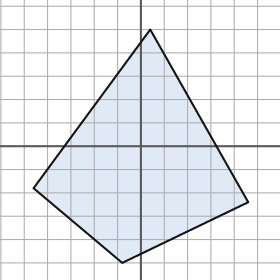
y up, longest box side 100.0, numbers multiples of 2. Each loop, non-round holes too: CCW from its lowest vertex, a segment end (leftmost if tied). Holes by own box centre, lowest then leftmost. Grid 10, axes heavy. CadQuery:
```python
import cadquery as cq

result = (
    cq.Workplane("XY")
    .moveTo(-8.0, -50.0)
    .lineTo(46.0, -24.0)
    .lineTo(4.0, 50.0)
    .lineTo(-46.0, -18.0)
    .close()
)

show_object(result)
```